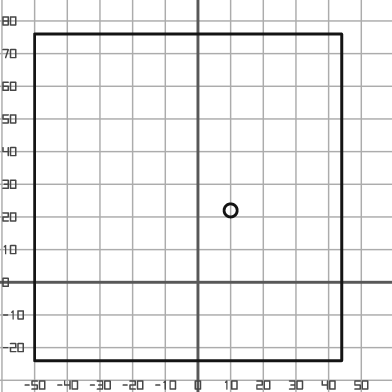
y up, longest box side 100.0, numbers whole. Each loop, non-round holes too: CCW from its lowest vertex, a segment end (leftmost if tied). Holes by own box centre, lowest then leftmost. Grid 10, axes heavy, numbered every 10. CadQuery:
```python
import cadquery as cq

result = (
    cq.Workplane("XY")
    .moveTo(-50.0, -24.0)
    .lineTo(44.0, -24.0)
    .lineTo(44.0, 76.0)
    .lineTo(-50.0, 76.0)
    .close()
    .moveTo(10.0, 22.0)
    .circle(2.0)
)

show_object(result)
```